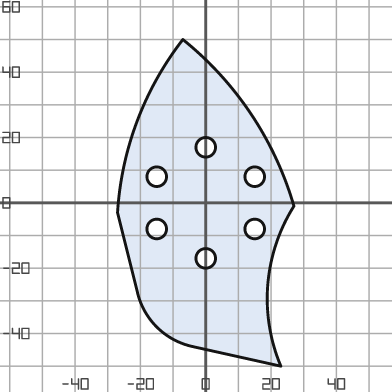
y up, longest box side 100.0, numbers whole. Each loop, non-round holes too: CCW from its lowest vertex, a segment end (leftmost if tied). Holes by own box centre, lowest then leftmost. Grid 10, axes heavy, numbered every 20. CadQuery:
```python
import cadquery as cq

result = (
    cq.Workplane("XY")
    .moveTo(23.0, -50.0)
    .threePointArc((19.0, -25.0), (27.0, -1.0))
    .threePointArc((14.0, 27.0), (-7.0, 50.0))
    .threePointArc((-21.0, 25.0), (-27.0, -3.0))
    .lineTo(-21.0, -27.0)
    .threePointArc((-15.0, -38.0), (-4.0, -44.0))
    .close()
    .moveTo(0.0, -17.0)
    .circle(3.0)
    .moveTo(-15.0, -8.0)
    .circle(3.0)
    .moveTo(15.0, -8.0)
    .circle(3.0)
    .moveTo(-15.0, 8.0)
    .circle(3.0)
    .moveTo(15.0, 8.0)
    .circle(3.0)
    .moveTo(0.0, 17.0)
    .circle(3.0)
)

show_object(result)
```